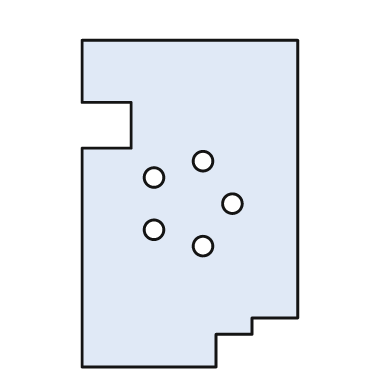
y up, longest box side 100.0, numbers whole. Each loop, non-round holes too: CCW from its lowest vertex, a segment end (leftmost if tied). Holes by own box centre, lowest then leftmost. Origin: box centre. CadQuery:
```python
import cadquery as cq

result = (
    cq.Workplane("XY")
    .moveTo(-33.0, -50.0)
    .lineTo(8.0, -50.0)
    .lineTo(8.0, -40.0)
    .lineTo(19.0, -40.0)
    .lineTo(19.0, -35.0)
    .lineTo(33.0, -35.0)
    .lineTo(33.0, 50.0)
    .lineTo(-33.0, 50.0)
    .lineTo(-33.0, 31.0)
    .lineTo(-18.0, 31.0)
    .lineTo(-18.0, 17.0)
    .lineTo(-33.0, 17.0)
    .close()
    .moveTo(4.0, -13.0)
    .circle(3.0)
    .moveTo(-11.0, -8.0)
    .circle(3.0)
    .moveTo(13.0, 0.0)
    .circle(3.0)
    .moveTo(-11.0, 8.0)
    .circle(3.0)
    .moveTo(4.0, 13.0)
    .circle(3.0)
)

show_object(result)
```